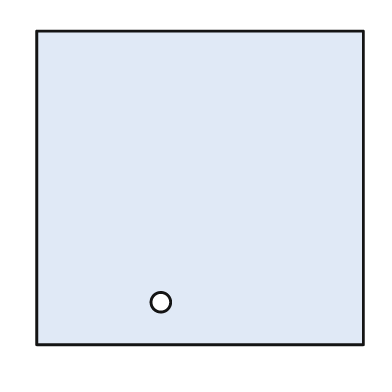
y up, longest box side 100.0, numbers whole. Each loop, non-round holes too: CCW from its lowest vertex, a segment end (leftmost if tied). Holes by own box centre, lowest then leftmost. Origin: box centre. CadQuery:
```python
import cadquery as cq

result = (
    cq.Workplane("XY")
    .moveTo(-50.0, -48.0)
    .lineTo(50.0, -48.0)
    .lineTo(50.0, 48.0)
    .lineTo(-50.0, 48.0)
    .close()
    .moveTo(-12.0, -35.0)
    .circle(3.0)
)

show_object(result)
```